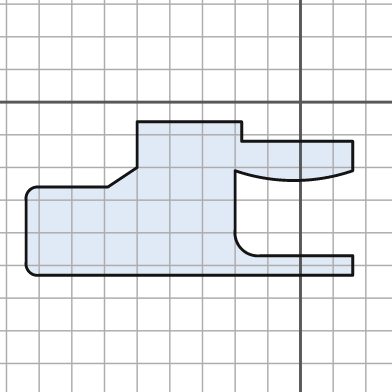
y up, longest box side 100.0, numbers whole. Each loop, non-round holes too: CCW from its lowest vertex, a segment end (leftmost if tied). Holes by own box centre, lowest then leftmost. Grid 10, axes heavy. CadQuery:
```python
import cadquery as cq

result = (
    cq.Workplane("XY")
    .moveTo(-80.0, -53.0)
    .lineTo(16.0, -53.0)
    .lineTo(16.0, -47.0)
    .lineTo(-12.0, -47.0)
    .threePointArc((-18.0, -45.0), (-20.0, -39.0))
    .lineTo(-20.0, -21.0)
    .threePointArc((-2.0, -24.0), (16.0, -21.0))
    .lineTo(16.0, -12.0)
    .lineTo(-18.0, -12.0)
    .lineTo(-18.0, -6.0)
    .lineTo(-50.0, -6.0)
    .lineTo(-50.0, -20.0)
    .lineTo(-59.0, -26.0)
    .lineTo(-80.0, -26.0)
    .threePointArc((-83.0, -27.0), (-84.0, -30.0))
    .lineTo(-84.0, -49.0)
    .threePointArc((-83.0, -52.0), (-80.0, -53.0))
    .close()
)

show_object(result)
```